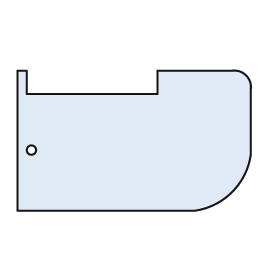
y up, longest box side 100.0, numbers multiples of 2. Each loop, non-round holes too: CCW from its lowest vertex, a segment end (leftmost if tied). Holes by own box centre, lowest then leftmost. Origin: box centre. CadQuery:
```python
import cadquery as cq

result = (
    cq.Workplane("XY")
    .moveTo(-50.0, -30.0)
    .lineTo(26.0, -30.0)
    .threePointArc((42.0, -22.0), (50.0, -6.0))
    .lineTo(50.0, 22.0)
    .threePointArc((48.0, 28.0), (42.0, 30.0))
    .lineTo(10.0, 30.0)
    .lineTo(10.0, 20.0)
    .lineTo(-46.0, 20.0)
    .lineTo(-46.0, 30.0)
    .lineTo(-50.0, 30.0)
    .close()
    .moveTo(-44.0, -4.0)
    .circle(2.0)
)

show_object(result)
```